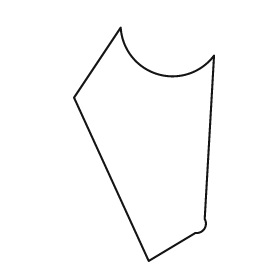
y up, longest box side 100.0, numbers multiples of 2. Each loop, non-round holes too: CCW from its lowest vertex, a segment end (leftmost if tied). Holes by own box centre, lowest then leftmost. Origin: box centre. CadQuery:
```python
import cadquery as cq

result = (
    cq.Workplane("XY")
    .moveTo(2.0, -50.0)
    .lineTo(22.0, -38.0)
    .threePointArc((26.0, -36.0), (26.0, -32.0))
    .lineTo(30.0, 38.0)
    .threePointArc((6.0, 30.0), (-10.0, 50.0))
    .lineTo(-30.0, 20.0)
    .close()
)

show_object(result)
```